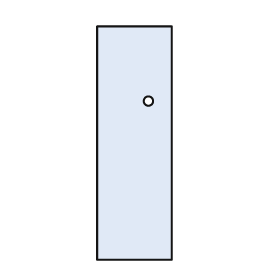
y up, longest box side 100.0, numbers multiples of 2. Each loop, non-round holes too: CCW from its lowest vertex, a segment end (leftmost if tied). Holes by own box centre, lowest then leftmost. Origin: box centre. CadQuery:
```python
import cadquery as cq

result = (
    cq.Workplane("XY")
    .moveTo(-16.0, -50.0)
    .lineTo(16.0, -50.0)
    .lineTo(16.0, 50.0)
    .lineTo(-16.0, 50.0)
    .close()
    .moveTo(6.0, 18.0)
    .circle(2.0)
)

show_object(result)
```